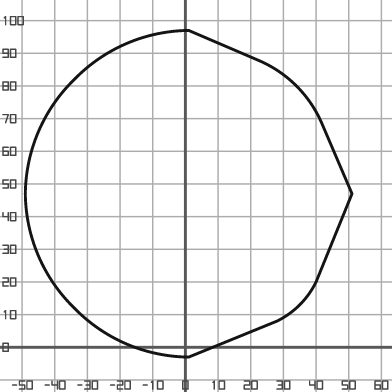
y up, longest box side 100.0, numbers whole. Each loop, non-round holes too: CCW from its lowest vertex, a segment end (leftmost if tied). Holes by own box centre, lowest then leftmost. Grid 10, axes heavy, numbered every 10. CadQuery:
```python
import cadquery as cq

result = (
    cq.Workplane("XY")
    .moveTo(1.0, -3.0)
    .lineTo(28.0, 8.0)
    .threePointArc((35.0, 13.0), (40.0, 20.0))
    .lineTo(51.0, 47.0)
    .lineTo(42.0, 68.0)
    .threePointArc((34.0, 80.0), (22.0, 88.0))
    .lineTo(1.0, 97.0)
    .threePointArc((-18.0, 93.0), (-34.0, 82.0))
    .threePointArc((-45.0, 66.0), (-49.0, 47.0))
    .threePointArc((-45.0, 28.0), (-34.0, 12.0))
    .threePointArc((-18.0, 1.0), (1.0, -3.0))
    .close()
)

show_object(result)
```